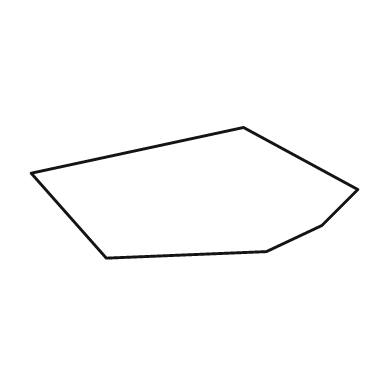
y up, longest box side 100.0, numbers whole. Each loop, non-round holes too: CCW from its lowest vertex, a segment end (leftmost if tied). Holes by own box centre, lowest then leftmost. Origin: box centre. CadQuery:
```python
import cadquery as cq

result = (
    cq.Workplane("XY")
    .moveTo(-27.0, -20.0)
    .lineTo(22.0, -18.0)
    .lineTo(39.0, -10.0)
    .lineTo(50.0, 1.0)
    .lineTo(15.0, 20.0)
    .lineTo(-50.0, 6.0)
    .close()
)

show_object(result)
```